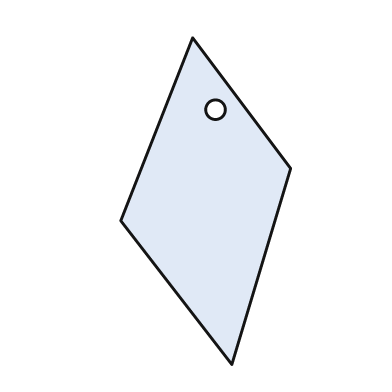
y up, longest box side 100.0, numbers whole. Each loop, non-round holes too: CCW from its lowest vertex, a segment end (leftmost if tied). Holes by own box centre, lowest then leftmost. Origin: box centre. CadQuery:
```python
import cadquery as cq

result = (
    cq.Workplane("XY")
    .moveTo(8.0, -50.0)
    .lineTo(26.0, 10.0)
    .lineTo(-4.0, 50.0)
    .lineTo(-26.0, -6.0)
    .close()
    .moveTo(3.0, 28.0)
    .circle(3.0)
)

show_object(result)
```